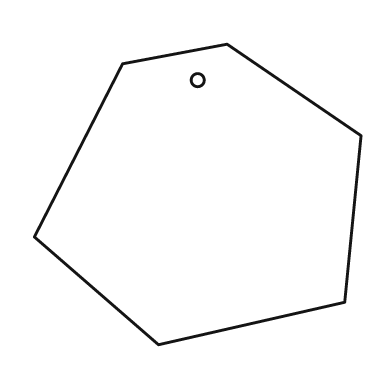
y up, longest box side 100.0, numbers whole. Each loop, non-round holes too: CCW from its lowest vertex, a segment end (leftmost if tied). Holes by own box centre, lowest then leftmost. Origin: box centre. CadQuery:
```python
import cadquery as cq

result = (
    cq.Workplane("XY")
    .moveTo(-12.0, -46.0)
    .lineTo(45.0, -33.0)
    .lineTo(50.0, 18.0)
    .lineTo(9.0, 46.0)
    .lineTo(-23.0, 40.0)
    .lineTo(-50.0, -13.0)
    .close()
    .moveTo(0.0, 35.0)
    .circle(2.0)
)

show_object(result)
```